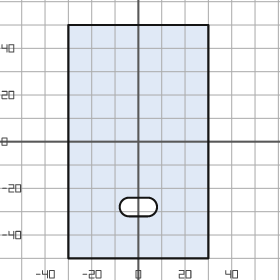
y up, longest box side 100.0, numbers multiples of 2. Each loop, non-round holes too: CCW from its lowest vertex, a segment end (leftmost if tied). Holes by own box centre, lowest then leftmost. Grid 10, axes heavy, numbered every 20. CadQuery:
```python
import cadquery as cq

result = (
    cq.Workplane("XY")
    .moveTo(-30.0, -50.0)
    .lineTo(30.0, -50.0)
    .lineTo(30.0, 50.0)
    .lineTo(-30.0, 50.0)
    .close()
    .moveTo(-4.0, -32.0)
    .lineTo(4.0, -32.0)
    .threePointArc((8.0, -28.0), (4.0, -24.0))
    .lineTo(-4.0, -24.0)
    .threePointArc((-8.0, -28.0), (-4.0, -32.0))
    .close()
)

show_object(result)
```